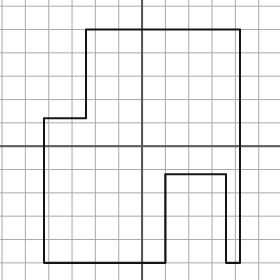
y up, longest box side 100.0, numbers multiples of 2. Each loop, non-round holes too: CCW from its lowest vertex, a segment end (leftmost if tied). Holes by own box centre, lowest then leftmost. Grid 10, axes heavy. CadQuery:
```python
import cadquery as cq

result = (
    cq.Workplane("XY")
    .moveTo(-42.0, -50.0)
    .lineTo(10.0, -50.0)
    .lineTo(10.0, -12.0)
    .lineTo(36.0, -12.0)
    .lineTo(36.0, -50.0)
    .lineTo(42.0, -50.0)
    .lineTo(42.0, 50.0)
    .lineTo(-24.0, 50.0)
    .lineTo(-24.0, 12.0)
    .lineTo(-42.0, 12.0)
    .close()
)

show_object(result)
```